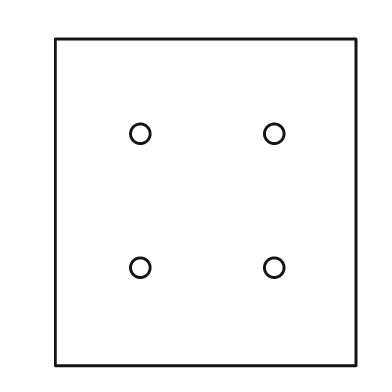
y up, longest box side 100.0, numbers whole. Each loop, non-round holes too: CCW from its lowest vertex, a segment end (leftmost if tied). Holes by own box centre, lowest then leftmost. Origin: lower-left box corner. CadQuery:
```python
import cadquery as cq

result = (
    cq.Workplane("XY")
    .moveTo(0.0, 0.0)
    .lineTo(92.0, 0.0)
    .lineTo(92.0, 100.0)
    .lineTo(0.0, 100.0)
    .close()
    .moveTo(26.0, 30.0)
    .circle(3.0)
    .moveTo(67.0, 30.0)
    .circle(3.0)
    .moveTo(26.0, 71.0)
    .circle(3.0)
    .moveTo(67.0, 71.0)
    .circle(3.0)
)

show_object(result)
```